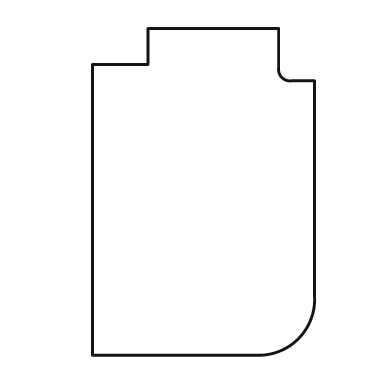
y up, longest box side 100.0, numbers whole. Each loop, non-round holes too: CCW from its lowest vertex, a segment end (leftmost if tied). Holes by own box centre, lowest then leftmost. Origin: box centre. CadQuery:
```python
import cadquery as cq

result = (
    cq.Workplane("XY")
    .moveTo(-34.0, -50.0)
    .lineTo(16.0, -50.0)
    .threePointArc((29.0, -45.0), (34.0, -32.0))
    .lineTo(34.0, 34.0)
    .lineTo(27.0, 34.0)
    .threePointArc((24.0, 35.0), (23.0, 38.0))
    .lineTo(23.0, 50.0)
    .lineTo(-17.0, 50.0)
    .lineTo(-17.0, 39.0)
    .lineTo(-34.0, 39.0)
    .close()
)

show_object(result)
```